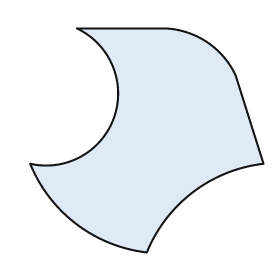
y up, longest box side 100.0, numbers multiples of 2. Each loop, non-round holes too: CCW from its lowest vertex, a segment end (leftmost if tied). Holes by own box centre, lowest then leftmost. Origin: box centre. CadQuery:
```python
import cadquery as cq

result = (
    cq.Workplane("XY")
    .moveTo(0.0, -48.0)
    .threePointArc((20.0, -22.0), (50.0, -10.0))
    .lineTo(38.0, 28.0)
    .threePointArc((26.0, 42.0), (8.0, 48.0))
    .lineTo(-30.0, 48.0)
    .threePointArc((-14.0, 10.0), (-50.0, -10.0))
    .threePointArc((-30.0, -36.0), (0.0, -48.0))
    .close()
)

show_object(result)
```